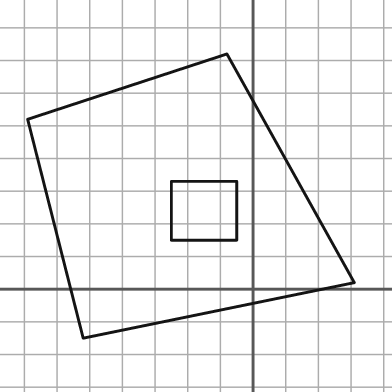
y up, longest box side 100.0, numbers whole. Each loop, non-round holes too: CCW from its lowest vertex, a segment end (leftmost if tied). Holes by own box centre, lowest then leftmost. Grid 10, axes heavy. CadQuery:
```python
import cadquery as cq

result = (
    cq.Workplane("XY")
    .moveTo(-52.0, -15.0)
    .lineTo(31.0, 2.0)
    .lineTo(-8.0, 72.0)
    .lineTo(-69.0, 52.0)
    .close()
    .moveTo(-25.0, 15.0)
    .lineTo(-5.0, 15.0)
    .lineTo(-5.0, 33.0)
    .lineTo(-25.0, 33.0)
    .close()
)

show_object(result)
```